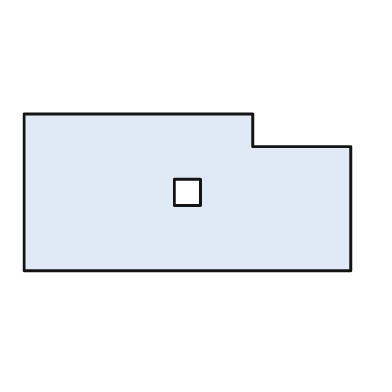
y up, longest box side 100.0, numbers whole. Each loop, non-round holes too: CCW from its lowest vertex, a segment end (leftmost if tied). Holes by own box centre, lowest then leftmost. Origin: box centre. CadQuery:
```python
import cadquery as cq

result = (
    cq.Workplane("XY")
    .moveTo(-50.0, -24.0)
    .lineTo(50.0, -24.0)
    .lineTo(50.0, 14.0)
    .lineTo(20.0, 14.0)
    .lineTo(20.0, 24.0)
    .lineTo(-50.0, 24.0)
    .close()
    .moveTo(-4.0, -4.0)
    .lineTo(4.0, -4.0)
    .lineTo(4.0, 4.0)
    .lineTo(-4.0, 4.0)
    .close()
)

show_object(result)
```